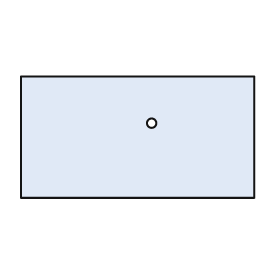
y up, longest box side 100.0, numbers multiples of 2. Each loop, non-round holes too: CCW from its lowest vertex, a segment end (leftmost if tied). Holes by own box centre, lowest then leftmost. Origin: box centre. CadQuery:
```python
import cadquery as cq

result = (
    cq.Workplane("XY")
    .moveTo(-50.0, -26.0)
    .lineTo(50.0, -26.0)
    .lineTo(50.0, 26.0)
    .lineTo(-50.0, 26.0)
    .close()
    .moveTo(6.0, 6.0)
    .circle(2.0)
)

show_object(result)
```